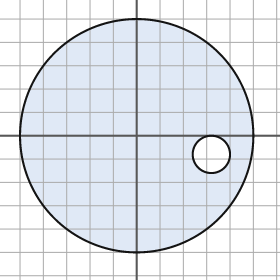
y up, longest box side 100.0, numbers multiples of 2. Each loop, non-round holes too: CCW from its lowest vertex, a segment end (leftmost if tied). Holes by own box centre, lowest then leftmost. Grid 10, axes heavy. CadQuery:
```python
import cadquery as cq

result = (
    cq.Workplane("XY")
    .moveTo(0.0, 0.0)
    .circle(50.0)
    .moveTo(32.0, -8.0)
    .circle(8.0)
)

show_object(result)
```